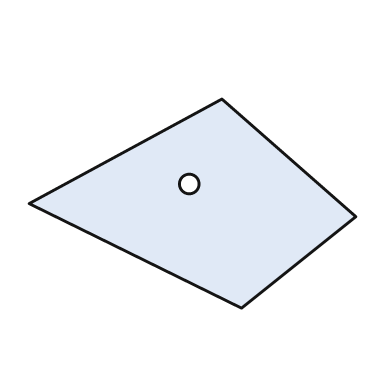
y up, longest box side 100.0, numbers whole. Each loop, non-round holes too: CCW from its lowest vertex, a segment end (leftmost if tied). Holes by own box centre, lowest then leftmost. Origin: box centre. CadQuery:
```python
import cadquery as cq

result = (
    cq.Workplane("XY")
    .moveTo(15.0, -32.0)
    .lineTo(50.0, -4.0)
    .lineTo(9.0, 32.0)
    .lineTo(-50.0, 0.0)
    .close()
    .moveTo(-1.0, 6.0)
    .circle(3.0)
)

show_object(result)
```